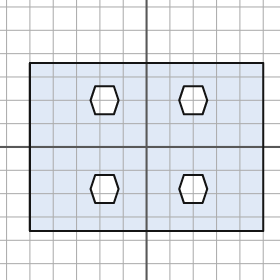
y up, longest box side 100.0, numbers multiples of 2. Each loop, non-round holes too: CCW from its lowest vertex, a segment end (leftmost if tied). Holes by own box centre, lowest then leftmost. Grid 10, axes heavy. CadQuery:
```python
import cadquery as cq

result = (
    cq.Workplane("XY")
    .moveTo(-50.0, -36.0)
    .lineTo(50.0, -36.0)
    .lineTo(50.0, 36.0)
    .lineTo(-50.0, 36.0)
    .close()
    .moveTo(-22.0, -24.0)
    .lineTo(-14.0, -24.0)
    .lineTo(-12.0, -18.0)
    .lineTo(-14.0, -12.0)
    .lineTo(-22.0, -12.0)
    .lineTo(-24.0, -18.0)
    .close()
    .moveTo(16.0, -24.0)
    .lineTo(24.0, -24.0)
    .lineTo(26.0, -18.0)
    .lineTo(24.0, -12.0)
    .lineTo(16.0, -12.0)
    .lineTo(14.0, -18.0)
    .close()
    .moveTo(-22.0, 14.0)
    .lineTo(-14.0, 14.0)
    .lineTo(-12.0, 20.0)
    .lineTo(-14.0, 26.0)
    .lineTo(-22.0, 26.0)
    .lineTo(-24.0, 20.0)
    .close()
    .moveTo(16.0, 14.0)
    .lineTo(24.0, 14.0)
    .lineTo(26.0, 20.0)
    .lineTo(24.0, 26.0)
    .lineTo(16.0, 26.0)
    .lineTo(14.0, 20.0)
    .close()
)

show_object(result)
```